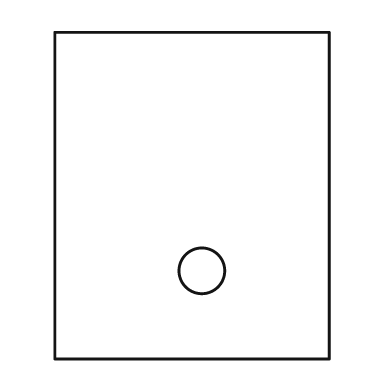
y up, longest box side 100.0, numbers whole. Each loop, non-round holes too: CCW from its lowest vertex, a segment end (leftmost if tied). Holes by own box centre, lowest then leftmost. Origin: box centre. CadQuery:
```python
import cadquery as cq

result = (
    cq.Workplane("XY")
    .moveTo(-42.0, -50.0)
    .lineTo(42.0, -50.0)
    .lineTo(42.0, 50.0)
    .lineTo(-42.0, 50.0)
    .close()
    .moveTo(3.0, -23.0)
    .circle(7.0)
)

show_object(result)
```